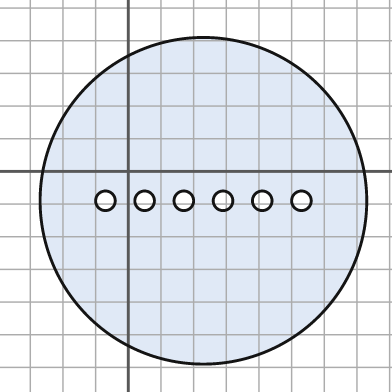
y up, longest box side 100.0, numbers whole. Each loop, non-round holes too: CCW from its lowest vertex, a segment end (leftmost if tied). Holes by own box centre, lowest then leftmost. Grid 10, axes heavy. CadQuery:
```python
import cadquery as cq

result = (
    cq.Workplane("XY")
    .moveTo(23.0, -9.0)
    .circle(50.0)
    .moveTo(-7.0, -9.0)
    .circle(3.0)
    .moveTo(5.0, -9.0)
    .circle(3.0)
    .moveTo(17.0, -9.0)
    .circle(3.0)
    .moveTo(29.0, -9.0)
    .circle(3.0)
    .moveTo(41.0, -9.0)
    .circle(3.0)
    .moveTo(53.0, -9.0)
    .circle(3.0)
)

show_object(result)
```